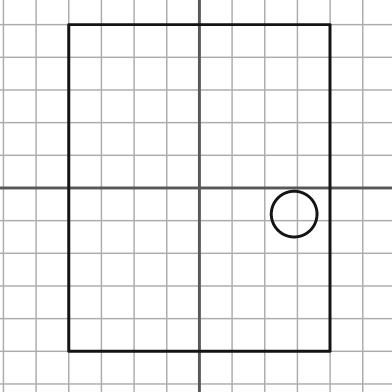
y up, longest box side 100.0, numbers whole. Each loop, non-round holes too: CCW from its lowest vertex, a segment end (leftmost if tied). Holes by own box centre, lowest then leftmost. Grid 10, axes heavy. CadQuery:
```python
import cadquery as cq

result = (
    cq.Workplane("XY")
    .moveTo(-40.0, -50.0)
    .lineTo(40.0, -50.0)
    .lineTo(40.0, 50.0)
    .lineTo(-40.0, 50.0)
    .close()
    .moveTo(29.0, -8.0)
    .circle(7.0)
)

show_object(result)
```